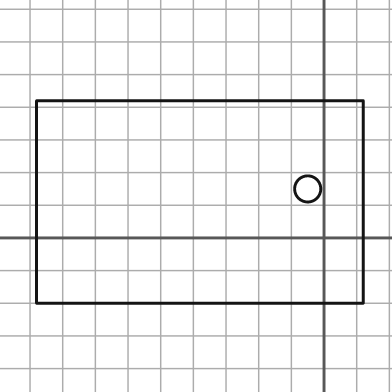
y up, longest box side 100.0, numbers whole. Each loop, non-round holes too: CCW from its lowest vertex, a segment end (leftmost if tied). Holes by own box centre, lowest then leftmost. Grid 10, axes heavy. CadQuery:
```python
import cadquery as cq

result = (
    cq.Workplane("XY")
    .moveTo(-88.0, -20.0)
    .lineTo(12.0, -20.0)
    .lineTo(12.0, 42.0)
    .lineTo(-88.0, 42.0)
    .close()
    .moveTo(-5.0, 15.0)
    .circle(4.0)
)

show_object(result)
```